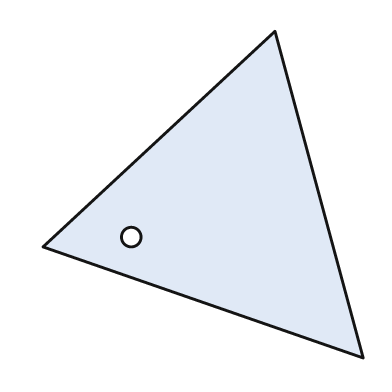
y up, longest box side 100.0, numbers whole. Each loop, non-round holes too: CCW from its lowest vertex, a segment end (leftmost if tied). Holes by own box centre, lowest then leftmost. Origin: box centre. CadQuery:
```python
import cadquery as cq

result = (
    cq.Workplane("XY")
    .moveTo(49.0, -50.0)
    .lineTo(22.0, 50.0)
    .lineTo(-49.0, -16.0)
    .close()
    .moveTo(-22.0, -13.0)
    .circle(3.0)
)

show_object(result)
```